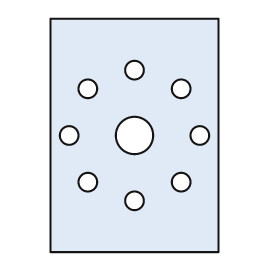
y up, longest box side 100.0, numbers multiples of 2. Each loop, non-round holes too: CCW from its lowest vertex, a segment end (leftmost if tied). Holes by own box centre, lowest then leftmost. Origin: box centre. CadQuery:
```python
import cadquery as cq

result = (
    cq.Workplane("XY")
    .moveTo(-36.0, -50.0)
    .lineTo(36.0, -50.0)
    .lineTo(36.0, 50.0)
    .lineTo(-36.0, 50.0)
    .close()
    .moveTo(0.0, -28.0)
    .circle(4.0)
    .moveTo(-20.0, -20.0)
    .circle(4.0)
    .moveTo(20.0, -20.0)
    .circle(4.0)
    .moveTo(-28.0, 0.0)
    .circle(4.0)
    .moveTo(0.0, 0.0)
    .circle(8.0)
    .moveTo(28.0, 0.0)
    .circle(4.0)
    .moveTo(-20.0, 20.0)
    .circle(4.0)
    .moveTo(20.0, 20.0)
    .circle(4.0)
    .moveTo(0.0, 28.0)
    .circle(4.0)
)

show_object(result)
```